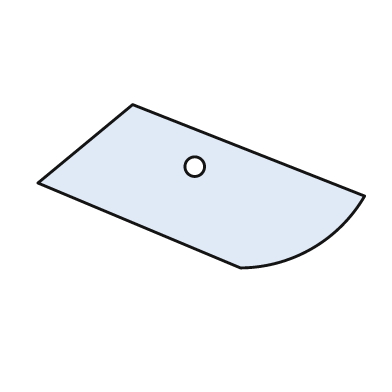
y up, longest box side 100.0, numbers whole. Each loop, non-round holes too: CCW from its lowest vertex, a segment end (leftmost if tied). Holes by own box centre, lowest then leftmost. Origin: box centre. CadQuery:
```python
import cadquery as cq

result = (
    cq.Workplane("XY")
    .moveTo(12.0, -25.0)
    .threePointArc((34.0, -19.0), (50.0, -3.0))
    .lineTo(-21.0, 25.0)
    .lineTo(-50.0, 1.0)
    .close()
    .moveTo(-2.0, 6.0)
    .circle(3.0)
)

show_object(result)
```